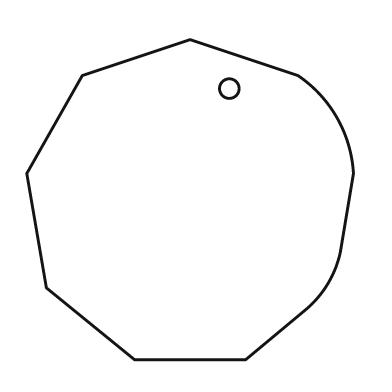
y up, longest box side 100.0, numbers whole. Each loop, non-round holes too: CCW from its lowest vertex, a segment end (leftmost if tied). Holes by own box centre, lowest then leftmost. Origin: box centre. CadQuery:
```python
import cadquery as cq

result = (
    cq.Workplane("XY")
    .moveTo(-17.0, -49.0)
    .lineTo(17.0, -49.0)
    .lineTo(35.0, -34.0)
    .threePointArc((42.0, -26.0), (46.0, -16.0))
    .lineTo(50.0, 8.0)
    .threePointArc((45.0, 25.0), (33.0, 38.0))
    .lineTo(0.0, 49.0)
    .lineTo(-33.0, 38.0)
    .lineTo(-50.0, 8.0)
    .lineTo(-44.0, -27.0)
    .close()
    .moveTo(12.0, 34.0)
    .circle(3.0)
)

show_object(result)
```